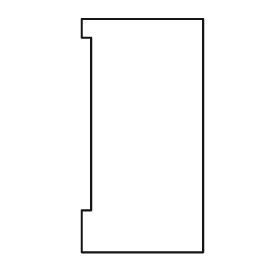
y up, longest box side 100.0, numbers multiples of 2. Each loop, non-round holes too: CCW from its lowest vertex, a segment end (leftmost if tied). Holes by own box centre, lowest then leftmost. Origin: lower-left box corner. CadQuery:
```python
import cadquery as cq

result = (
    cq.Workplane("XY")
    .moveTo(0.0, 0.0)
    .lineTo(52.0, 0.0)
    .lineTo(52.0, 100.0)
    .lineTo(0.0, 100.0)
    .lineTo(0.0, 92.0)
    .lineTo(4.0, 92.0)
    .lineTo(4.0, 18.0)
    .lineTo(0.0, 18.0)
    .close()
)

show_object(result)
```